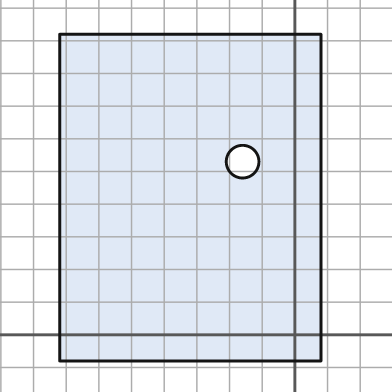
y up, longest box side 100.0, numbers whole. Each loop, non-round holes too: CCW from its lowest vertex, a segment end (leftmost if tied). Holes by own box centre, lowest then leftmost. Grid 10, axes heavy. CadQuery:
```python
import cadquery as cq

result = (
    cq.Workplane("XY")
    .moveTo(-72.0, -8.0)
    .lineTo(8.0, -8.0)
    .lineTo(8.0, 92.0)
    .lineTo(-72.0, 92.0)
    .close()
    .moveTo(-16.0, 53.0)
    .circle(5.0)
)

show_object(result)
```